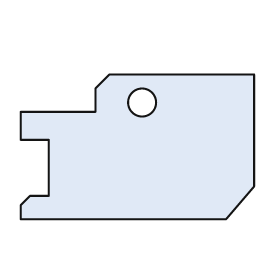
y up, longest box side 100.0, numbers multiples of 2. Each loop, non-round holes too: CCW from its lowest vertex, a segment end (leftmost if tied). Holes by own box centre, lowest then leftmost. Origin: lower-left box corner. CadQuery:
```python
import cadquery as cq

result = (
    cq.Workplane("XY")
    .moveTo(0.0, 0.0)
    .lineTo(88.0, 0.0)
    .lineTo(100.0, 14.0)
    .lineTo(100.0, 62.0)
    .lineTo(38.0, 62.0)
    .lineTo(32.0, 56.0)
    .lineTo(32.0, 46.0)
    .lineTo(0.0, 46.0)
    .lineTo(0.0, 34.0)
    .lineTo(12.0, 34.0)
    .lineTo(12.0, 10.0)
    .lineTo(4.0, 10.0)
    .lineTo(0.0, 6.0)
    .close()
    .moveTo(52.0, 50.0)
    .circle(6.0)
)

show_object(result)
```